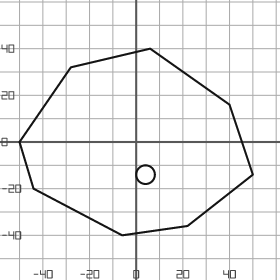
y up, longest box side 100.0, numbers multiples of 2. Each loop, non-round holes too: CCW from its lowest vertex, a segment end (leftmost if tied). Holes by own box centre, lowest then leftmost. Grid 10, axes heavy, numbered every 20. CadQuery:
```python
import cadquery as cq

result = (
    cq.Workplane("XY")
    .moveTo(-6.0, -40.0)
    .lineTo(22.0, -36.0)
    .lineTo(50.0, -14.0)
    .lineTo(40.0, 16.0)
    .lineTo(6.0, 40.0)
    .lineTo(-28.0, 32.0)
    .lineTo(-50.0, 0.0)
    .lineTo(-44.0, -20.0)
    .close()
    .moveTo(4.0, -14.0)
    .circle(4.0)
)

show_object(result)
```